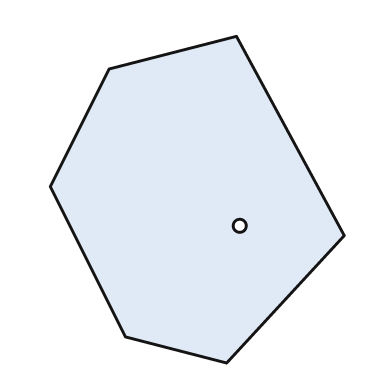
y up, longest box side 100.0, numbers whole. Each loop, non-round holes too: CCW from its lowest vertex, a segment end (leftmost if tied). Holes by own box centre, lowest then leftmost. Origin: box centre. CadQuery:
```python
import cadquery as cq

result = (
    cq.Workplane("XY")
    .moveTo(9.0, -50.0)
    .lineTo(45.0, -11.0)
    .lineTo(12.0, 50.0)
    .lineTo(-27.0, 40.0)
    .lineTo(-45.0, 4.0)
    .lineTo(-22.0, -42.0)
    .close()
    .moveTo(13.0, -8.0)
    .circle(2.0)
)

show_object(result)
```